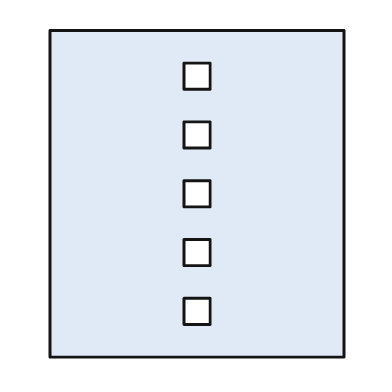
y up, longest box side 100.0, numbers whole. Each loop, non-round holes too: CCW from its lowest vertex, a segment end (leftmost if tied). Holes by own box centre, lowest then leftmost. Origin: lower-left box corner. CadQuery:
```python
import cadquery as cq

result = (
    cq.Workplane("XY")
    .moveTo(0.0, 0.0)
    .lineTo(90.0, 0.0)
    .lineTo(90.0, 100.0)
    .lineTo(0.0, 100.0)
    .close()
    .moveTo(41.0, 10.0)
    .lineTo(49.0, 10.0)
    .lineTo(49.0, 18.0)
    .lineTo(41.0, 18.0)
    .close()
    .moveTo(41.0, 28.0)
    .lineTo(49.0, 28.0)
    .lineTo(49.0, 36.0)
    .lineTo(41.0, 36.0)
    .close()
    .moveTo(41.0, 46.0)
    .lineTo(49.0, 46.0)
    .lineTo(49.0, 54.0)
    .lineTo(41.0, 54.0)
    .close()
    .moveTo(41.0, 64.0)
    .lineTo(49.0, 64.0)
    .lineTo(49.0, 72.0)
    .lineTo(41.0, 72.0)
    .close()
    .moveTo(41.0, 82.0)
    .lineTo(49.0, 82.0)
    .lineTo(49.0, 90.0)
    .lineTo(41.0, 90.0)
    .close()
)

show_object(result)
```